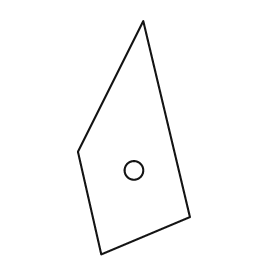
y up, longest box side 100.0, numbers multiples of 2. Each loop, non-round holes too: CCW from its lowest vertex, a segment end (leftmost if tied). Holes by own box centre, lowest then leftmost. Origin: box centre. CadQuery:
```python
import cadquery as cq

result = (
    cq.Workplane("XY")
    .moveTo(-14.0, -50.0)
    .lineTo(24.0, -34.0)
    .lineTo(4.0, 50.0)
    .lineTo(-24.0, -6.0)
    .close()
    .moveTo(0.0, -14.0)
    .circle(4.0)
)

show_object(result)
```